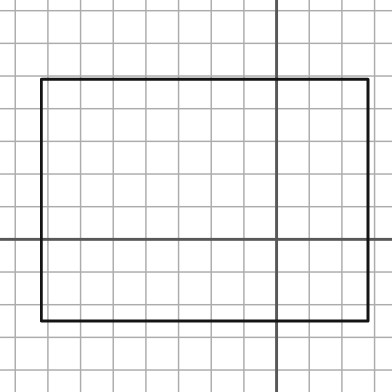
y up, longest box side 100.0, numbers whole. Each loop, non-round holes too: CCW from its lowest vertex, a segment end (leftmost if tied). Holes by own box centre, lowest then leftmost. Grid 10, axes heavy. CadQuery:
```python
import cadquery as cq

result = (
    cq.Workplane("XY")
    .moveTo(-72.0, -25.0)
    .lineTo(28.0, -25.0)
    .lineTo(28.0, 49.0)
    .lineTo(-72.0, 49.0)
    .close()
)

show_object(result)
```